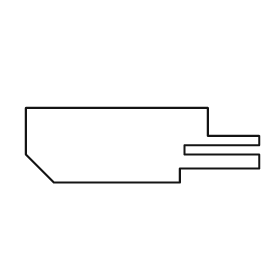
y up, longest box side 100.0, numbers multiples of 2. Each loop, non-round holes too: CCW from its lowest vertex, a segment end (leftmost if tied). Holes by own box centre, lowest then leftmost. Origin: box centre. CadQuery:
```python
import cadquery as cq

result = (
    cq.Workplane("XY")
    .moveTo(-38.0, -16.0)
    .lineTo(16.0, -16.0)
    .lineTo(16.0, -10.0)
    .lineTo(50.0, -10.0)
    .lineTo(50.0, -4.0)
    .lineTo(18.0, -4.0)
    .lineTo(18.0, 0.0)
    .lineTo(50.0, 0.0)
    .lineTo(50.0, 4.0)
    .lineTo(28.0, 4.0)
    .lineTo(28.0, 16.0)
    .lineTo(-50.0, 16.0)
    .lineTo(-50.0, -4.0)
    .close()
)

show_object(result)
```